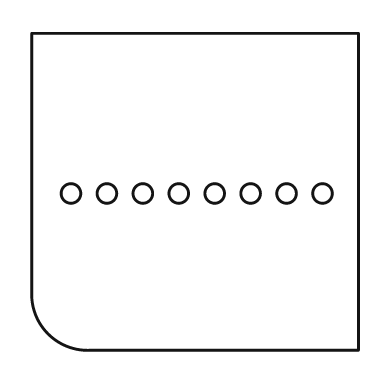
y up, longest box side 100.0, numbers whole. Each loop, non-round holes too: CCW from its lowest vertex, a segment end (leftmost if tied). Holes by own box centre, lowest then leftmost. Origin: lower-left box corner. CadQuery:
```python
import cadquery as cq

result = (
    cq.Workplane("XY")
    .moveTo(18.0, 0.0)
    .lineTo(100.0, 0.0)
    .lineTo(100.0, 97.0)
    .lineTo(0.0, 97.0)
    .lineTo(0.0, 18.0)
    .threePointArc((5.0, 5.0), (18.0, 0.0))
    .close()
    .moveTo(12.0, 48.0)
    .circle(3.0)
    .moveTo(23.0, 48.0)
    .circle(3.0)
    .moveTo(34.0, 48.0)
    .circle(3.0)
    .moveTo(45.0, 48.0)
    .circle(3.0)
    .moveTo(56.0, 48.0)
    .circle(3.0)
    .moveTo(67.0, 48.0)
    .circle(3.0)
    .moveTo(78.0, 48.0)
    .circle(3.0)
    .moveTo(89.0, 48.0)
    .circle(3.0)
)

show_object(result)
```